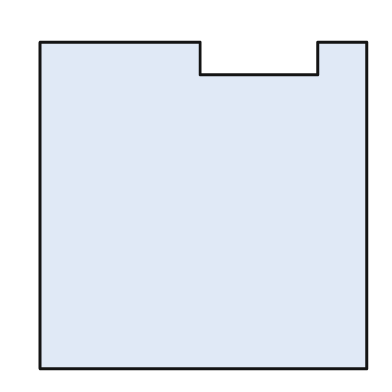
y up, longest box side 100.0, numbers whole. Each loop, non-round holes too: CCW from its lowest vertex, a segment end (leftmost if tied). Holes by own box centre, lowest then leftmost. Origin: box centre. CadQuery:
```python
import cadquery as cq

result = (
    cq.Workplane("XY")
    .moveTo(-50.0, -50.0)
    .lineTo(50.0, -50.0)
    .lineTo(50.0, 50.0)
    .lineTo(35.0, 50.0)
    .lineTo(35.0, 40.0)
    .lineTo(-1.0, 40.0)
    .lineTo(-1.0, 50.0)
    .lineTo(-50.0, 50.0)
    .close()
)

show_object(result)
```